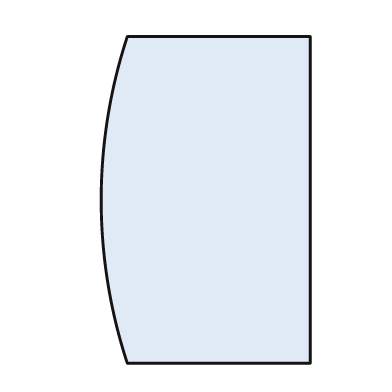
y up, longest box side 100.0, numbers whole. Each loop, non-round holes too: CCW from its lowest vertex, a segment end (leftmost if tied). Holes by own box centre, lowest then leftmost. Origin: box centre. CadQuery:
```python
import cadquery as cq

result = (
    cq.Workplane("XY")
    .moveTo(-24.0, -50.0)
    .lineTo(32.0, -50.0)
    .lineTo(32.0, 50.0)
    .lineTo(-24.0, 50.0)
    .threePointArc((-32.0, 0.0), (-24.0, -50.0))
    .close()
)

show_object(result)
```